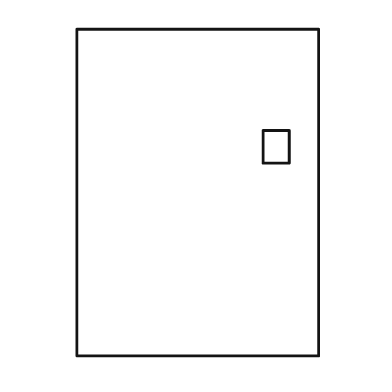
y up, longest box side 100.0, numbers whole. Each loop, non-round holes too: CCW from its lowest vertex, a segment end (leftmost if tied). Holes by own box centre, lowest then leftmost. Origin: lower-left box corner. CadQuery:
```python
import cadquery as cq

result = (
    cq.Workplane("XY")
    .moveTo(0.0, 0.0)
    .lineTo(74.0, 0.0)
    .lineTo(74.0, 100.0)
    .lineTo(0.0, 100.0)
    .close()
    .moveTo(57.0, 59.0)
    .lineTo(65.0, 59.0)
    .lineTo(65.0, 69.0)
    .lineTo(57.0, 69.0)
    .close()
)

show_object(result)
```